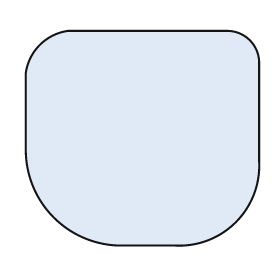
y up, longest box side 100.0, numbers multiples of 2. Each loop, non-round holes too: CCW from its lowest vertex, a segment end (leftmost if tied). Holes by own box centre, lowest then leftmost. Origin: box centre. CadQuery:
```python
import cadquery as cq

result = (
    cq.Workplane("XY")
    .moveTo(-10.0, -46.0)
    .lineTo(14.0, -46.0)
    .threePointArc((40.0, -36.0), (50.0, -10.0))
    .lineTo(50.0, 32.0)
    .threePointArc((46.0, 42.0), (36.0, 46.0))
    .lineTo(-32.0, 46.0)
    .threePointArc((-44.0, 40.0), (-50.0, 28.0))
    .lineTo(-50.0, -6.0)
    .threePointArc((-38.0, -34.0), (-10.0, -46.0))
    .close()
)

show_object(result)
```